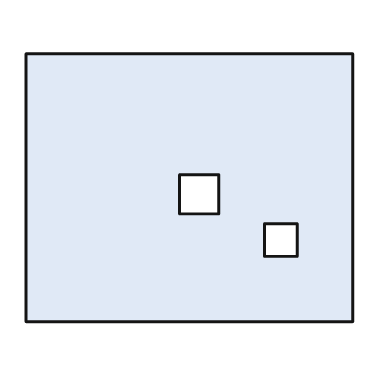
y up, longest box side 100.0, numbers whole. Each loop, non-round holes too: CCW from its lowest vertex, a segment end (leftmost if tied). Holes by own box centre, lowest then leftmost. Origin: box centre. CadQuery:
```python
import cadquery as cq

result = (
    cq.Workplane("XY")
    .moveTo(-50.0, -41.0)
    .lineTo(50.0, -41.0)
    .lineTo(50.0, 41.0)
    .lineTo(-50.0, 41.0)
    .close()
    .moveTo(23.0, -21.0)
    .lineTo(33.0, -21.0)
    .lineTo(33.0, -11.0)
    .lineTo(23.0, -11.0)
    .close()
    .moveTo(-3.0, -8.0)
    .lineTo(9.0, -8.0)
    .lineTo(9.0, 4.0)
    .lineTo(-3.0, 4.0)
    .close()
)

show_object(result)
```